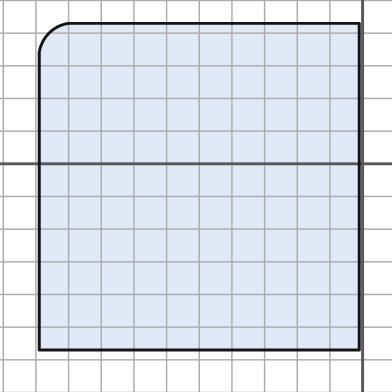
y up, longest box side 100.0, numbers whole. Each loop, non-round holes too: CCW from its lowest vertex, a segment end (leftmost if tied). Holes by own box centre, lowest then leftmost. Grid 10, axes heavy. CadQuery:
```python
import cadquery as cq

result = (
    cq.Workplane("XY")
    .moveTo(-99.0, -57.0)
    .lineTo(-1.0, -57.0)
    .lineTo(-1.0, 43.0)
    .lineTo(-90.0, 43.0)
    .threePointArc((-96.0, 40.0), (-99.0, 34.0))
    .close()
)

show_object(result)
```